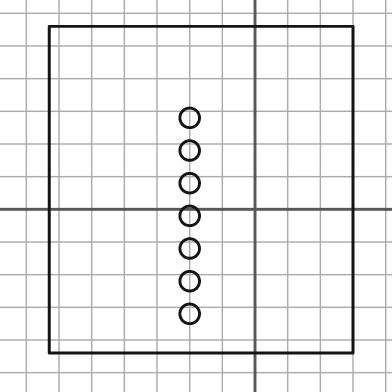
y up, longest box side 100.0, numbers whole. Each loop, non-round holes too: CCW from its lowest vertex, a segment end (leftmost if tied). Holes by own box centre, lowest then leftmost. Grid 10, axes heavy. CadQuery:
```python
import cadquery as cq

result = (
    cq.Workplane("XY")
    .moveTo(-63.0, -44.0)
    .lineTo(30.0, -44.0)
    .lineTo(30.0, 56.0)
    .lineTo(-63.0, 56.0)
    .close()
    .moveTo(-20.0, -32.0)
    .circle(3.0)
    .moveTo(-20.0, -22.0)
    .circle(3.0)
    .moveTo(-20.0, -12.0)
    .circle(3.0)
    .moveTo(-20.0, -2.0)
    .circle(3.0)
    .moveTo(-20.0, 8.0)
    .circle(3.0)
    .moveTo(-20.0, 18.0)
    .circle(3.0)
    .moveTo(-20.0, 28.0)
    .circle(3.0)
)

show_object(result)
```